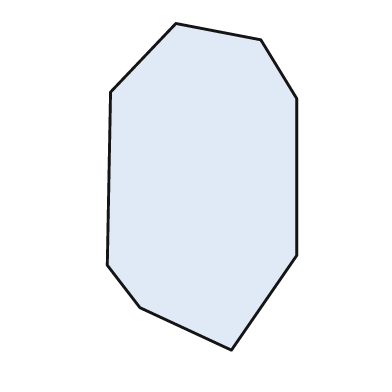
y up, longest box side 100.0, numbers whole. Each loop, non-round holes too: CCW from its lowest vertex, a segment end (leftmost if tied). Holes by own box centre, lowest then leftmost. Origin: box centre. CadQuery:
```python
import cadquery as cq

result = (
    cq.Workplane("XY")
    .moveTo(9.0, -50.0)
    .lineTo(29.0, -21.0)
    .lineTo(29.0, 27.0)
    .lineTo(18.0, 45.0)
    .lineTo(-8.0, 50.0)
    .lineTo(-28.0, 29.0)
    .lineTo(-29.0, -24.0)
    .lineTo(-19.0, -37.0)
    .close()
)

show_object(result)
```